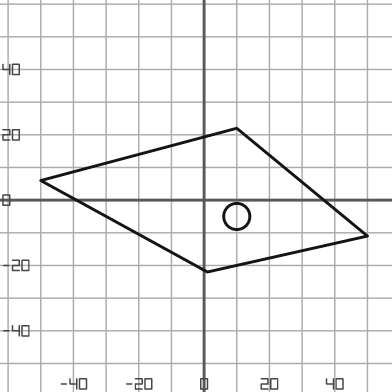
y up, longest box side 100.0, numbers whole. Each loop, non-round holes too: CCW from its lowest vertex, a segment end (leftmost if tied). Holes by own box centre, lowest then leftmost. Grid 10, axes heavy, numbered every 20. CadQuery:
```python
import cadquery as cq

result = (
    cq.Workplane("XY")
    .moveTo(1.0, -22.0)
    .lineTo(50.0, -11.0)
    .lineTo(10.0, 22.0)
    .lineTo(-50.0, 6.0)
    .close()
    .moveTo(10.0, -5.0)
    .circle(4.0)
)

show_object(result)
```